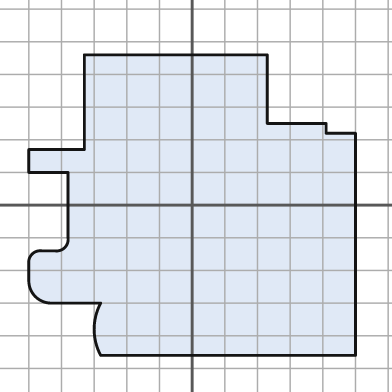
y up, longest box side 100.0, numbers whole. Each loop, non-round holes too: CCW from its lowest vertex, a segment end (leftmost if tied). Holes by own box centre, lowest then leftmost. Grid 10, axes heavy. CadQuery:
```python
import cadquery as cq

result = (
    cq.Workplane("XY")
    .moveTo(-28.0, -46.0)
    .lineTo(50.0, -46.0)
    .lineTo(50.0, 22.0)
    .lineTo(41.0, 22.0)
    .lineTo(41.0, 25.0)
    .lineTo(23.0, 25.0)
    .lineTo(23.0, 46.0)
    .lineTo(-33.0, 46.0)
    .lineTo(-33.0, 17.0)
    .lineTo(-50.0, 17.0)
    .lineTo(-50.0, 10.0)
    .lineTo(-38.0, 10.0)
    .lineTo(-38.0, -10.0)
    .threePointArc((-39.0, -13.0), (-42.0, -14.0))
    .lineTo(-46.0, -14.0)
    .threePointArc((-49.0, -15.0), (-50.0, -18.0))
    .lineTo(-50.0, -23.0)
    .threePointArc((-48.0, -28.0), (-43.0, -30.0))
    .lineTo(-28.0, -30.0)
    .threePointArc((-30.0, -38.0), (-28.0, -46.0))
    .close()
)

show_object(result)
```